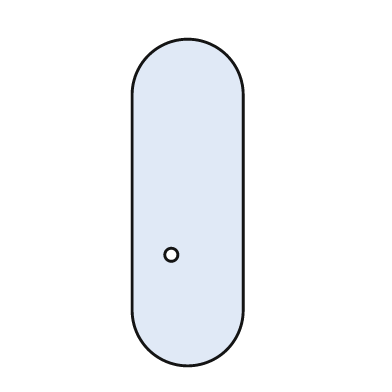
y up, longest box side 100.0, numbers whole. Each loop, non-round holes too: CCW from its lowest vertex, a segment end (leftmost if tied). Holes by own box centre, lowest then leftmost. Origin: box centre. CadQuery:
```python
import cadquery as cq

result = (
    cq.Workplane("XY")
    .moveTo(-17.0, -33.0)
    .threePointArc((0.0, -50.0), (17.0, -33.0))
    .lineTo(17.0, 33.0)
    .threePointArc((0.0, 50.0), (-17.0, 33.0))
    .close()
    .moveTo(-5.0, -16.0)
    .circle(2.0)
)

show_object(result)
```